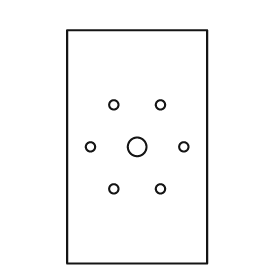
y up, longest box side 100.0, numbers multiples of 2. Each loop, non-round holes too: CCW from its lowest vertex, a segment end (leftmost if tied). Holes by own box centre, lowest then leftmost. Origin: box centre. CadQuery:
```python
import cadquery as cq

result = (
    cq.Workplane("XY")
    .moveTo(-30.0, -50.0)
    .lineTo(30.0, -50.0)
    .lineTo(30.0, 50.0)
    .lineTo(-30.0, 50.0)
    .close()
    .moveTo(-10.0, -18.0)
    .circle(2.0)
    .moveTo(10.0, -18.0)
    .circle(2.0)
    .moveTo(-20.0, 0.0)
    .circle(2.0)
    .moveTo(0.0, 0.0)
    .circle(4.0)
    .moveTo(20.0, 0.0)
    .circle(2.0)
    .moveTo(-10.0, 18.0)
    .circle(2.0)
    .moveTo(10.0, 18.0)
    .circle(2.0)
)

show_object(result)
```